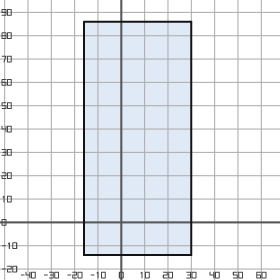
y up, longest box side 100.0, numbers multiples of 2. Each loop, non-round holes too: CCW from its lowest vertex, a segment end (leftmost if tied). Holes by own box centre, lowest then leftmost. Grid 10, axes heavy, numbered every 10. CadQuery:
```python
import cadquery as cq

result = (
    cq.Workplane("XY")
    .moveTo(-16.0, -14.0)
    .lineTo(30.0, -14.0)
    .lineTo(30.0, 86.0)
    .lineTo(-16.0, 86.0)
    .close()
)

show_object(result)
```